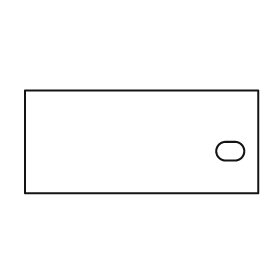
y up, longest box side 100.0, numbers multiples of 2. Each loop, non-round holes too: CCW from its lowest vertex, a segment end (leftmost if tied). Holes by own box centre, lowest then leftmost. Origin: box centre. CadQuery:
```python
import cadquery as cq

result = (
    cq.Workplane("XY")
    .moveTo(-50.0, -22.0)
    .lineTo(50.0, -22.0)
    .lineTo(50.0, 22.0)
    .lineTo(-50.0, 22.0)
    .close()
    .moveTo(36.0, -8.0)
    .lineTo(40.0, -8.0)
    .threePointArc((44.0, -4.0), (40.0, 0.0))
    .lineTo(36.0, 0.0)
    .threePointArc((32.0, -4.0), (36.0, -8.0))
    .close()
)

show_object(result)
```